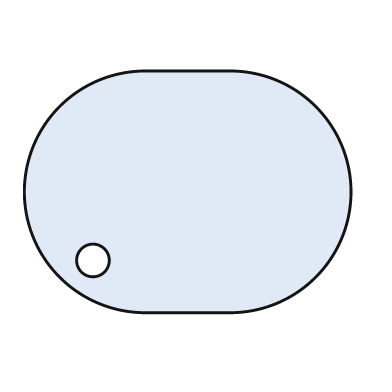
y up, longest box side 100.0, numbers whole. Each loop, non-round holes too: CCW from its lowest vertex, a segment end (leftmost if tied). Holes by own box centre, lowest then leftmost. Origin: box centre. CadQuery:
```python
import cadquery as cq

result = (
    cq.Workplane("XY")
    .moveTo(-13.0, -37.0)
    .lineTo(13.0, -37.0)
    .threePointArc((50.0, 0.0), (13.0, 37.0))
    .lineTo(-13.0, 37.0)
    .threePointArc((-50.0, 0.0), (-13.0, -37.0))
    .close()
    .moveTo(-29.0, -21.0)
    .circle(5.0)
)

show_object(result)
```